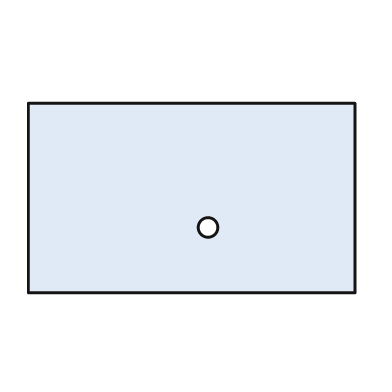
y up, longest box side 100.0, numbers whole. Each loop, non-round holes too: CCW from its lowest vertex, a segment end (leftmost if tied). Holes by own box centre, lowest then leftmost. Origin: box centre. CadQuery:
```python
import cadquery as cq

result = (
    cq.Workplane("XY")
    .moveTo(-50.0, -29.0)
    .lineTo(50.0, -29.0)
    .lineTo(50.0, 29.0)
    .lineTo(-50.0, 29.0)
    .close()
    .moveTo(5.0, -9.0)
    .circle(3.0)
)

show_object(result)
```